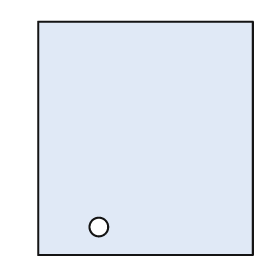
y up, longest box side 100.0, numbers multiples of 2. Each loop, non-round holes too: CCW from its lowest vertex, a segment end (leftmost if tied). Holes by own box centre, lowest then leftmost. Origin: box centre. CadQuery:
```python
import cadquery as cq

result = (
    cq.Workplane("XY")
    .moveTo(-46.0, -50.0)
    .lineTo(46.0, -50.0)
    .lineTo(46.0, 50.0)
    .lineTo(-46.0, 50.0)
    .close()
    .moveTo(-20.0, -38.0)
    .circle(4.0)
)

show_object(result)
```